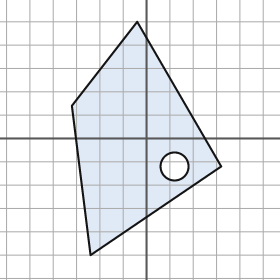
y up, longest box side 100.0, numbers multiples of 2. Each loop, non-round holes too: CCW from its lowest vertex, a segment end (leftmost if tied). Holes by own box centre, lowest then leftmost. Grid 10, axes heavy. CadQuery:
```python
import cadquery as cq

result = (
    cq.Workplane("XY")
    .moveTo(-24.0, -50.0)
    .lineTo(32.0, -12.0)
    .lineTo(-4.0, 50.0)
    .lineTo(-32.0, 14.0)
    .close()
    .moveTo(12.0, -12.0)
    .circle(6.0)
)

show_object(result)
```